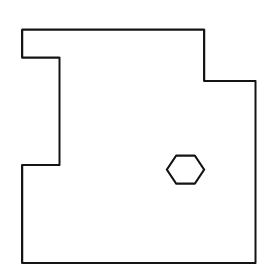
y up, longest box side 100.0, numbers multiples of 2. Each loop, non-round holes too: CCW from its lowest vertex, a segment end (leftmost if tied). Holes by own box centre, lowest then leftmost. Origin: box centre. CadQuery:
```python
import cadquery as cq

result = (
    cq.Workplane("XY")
    .moveTo(-50.0, -50.0)
    .lineTo(50.0, -50.0)
    .lineTo(50.0, 28.0)
    .lineTo(28.0, 28.0)
    .lineTo(28.0, 50.0)
    .lineTo(-50.0, 50.0)
    .lineTo(-50.0, 38.0)
    .lineTo(-34.0, 38.0)
    .lineTo(-34.0, -8.0)
    .lineTo(-50.0, -8.0)
    .close()
    .moveTo(16.0, -16.0)
    .lineTo(24.0, -16.0)
    .lineTo(28.0, -10.0)
    .lineTo(24.0, -4.0)
    .lineTo(16.0, -4.0)
    .lineTo(12.0, -10.0)
    .close()
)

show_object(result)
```